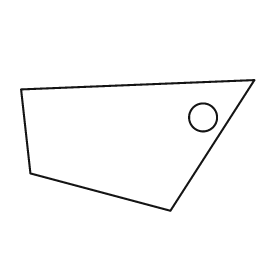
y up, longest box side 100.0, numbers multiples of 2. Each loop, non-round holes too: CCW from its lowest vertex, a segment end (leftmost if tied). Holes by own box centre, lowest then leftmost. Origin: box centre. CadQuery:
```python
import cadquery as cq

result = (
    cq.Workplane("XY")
    .moveTo(14.0, -28.0)
    .lineTo(50.0, 28.0)
    .lineTo(-50.0, 24.0)
    .lineTo(-46.0, -12.0)
    .close()
    .moveTo(28.0, 12.0)
    .circle(6.0)
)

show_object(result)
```